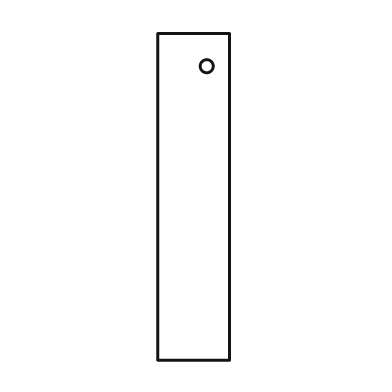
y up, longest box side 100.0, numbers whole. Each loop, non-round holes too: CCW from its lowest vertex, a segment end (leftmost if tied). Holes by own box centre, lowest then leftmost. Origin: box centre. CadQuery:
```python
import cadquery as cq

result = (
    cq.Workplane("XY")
    .moveTo(-11.0, -50.0)
    .lineTo(11.0, -50.0)
    .lineTo(11.0, 50.0)
    .lineTo(-11.0, 50.0)
    .close()
    .moveTo(4.0, 40.0)
    .circle(2.0)
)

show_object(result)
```